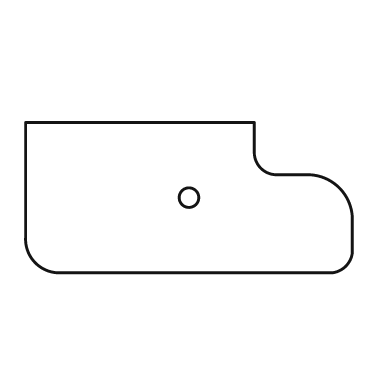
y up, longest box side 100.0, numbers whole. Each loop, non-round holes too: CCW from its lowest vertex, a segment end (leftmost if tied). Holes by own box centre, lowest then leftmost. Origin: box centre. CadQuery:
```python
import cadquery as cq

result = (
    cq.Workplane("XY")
    .moveTo(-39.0, -23.0)
    .lineTo(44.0, -23.0)
    .threePointArc((48.0, -21.0), (50.0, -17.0))
    .lineTo(50.0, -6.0)
    .threePointArc((46.0, 3.0), (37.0, 7.0))
    .lineTo(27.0, 7.0)
    .threePointArc((22.0, 9.0), (20.0, 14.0))
    .lineTo(20.0, 23.0)
    .lineTo(-50.0, 23.0)
    .lineTo(-50.0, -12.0)
    .threePointArc((-47.0, -20.0), (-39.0, -23.0))
    .close()
    .moveTo(0.0, 0.0)
    .circle(3.0)
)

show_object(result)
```